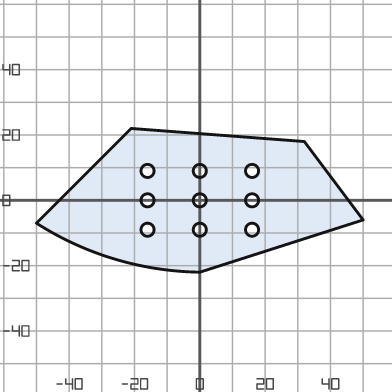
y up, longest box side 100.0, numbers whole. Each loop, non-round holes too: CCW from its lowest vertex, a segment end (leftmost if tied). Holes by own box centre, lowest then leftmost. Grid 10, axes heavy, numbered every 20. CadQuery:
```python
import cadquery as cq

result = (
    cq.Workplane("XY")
    .moveTo(0.0, -22.0)
    .lineTo(50.0, -6.0)
    .lineTo(32.0, 18.0)
    .lineTo(-21.0, 22.0)
    .lineTo(-50.0, -7.0)
    .threePointArc((-26.0, -18.0), (0.0, -22.0))
    .close()
    .moveTo(-16.0, -9.0)
    .circle(2.0)
    .moveTo(0.0, -9.0)
    .circle(2.0)
    .moveTo(16.0, -9.0)
    .circle(2.0)
    .moveTo(-16.0, 0.0)
    .circle(2.0)
    .moveTo(0.0, 0.0)
    .circle(2.0)
    .moveTo(16.0, 0.0)
    .circle(2.0)
    .moveTo(-16.0, 9.0)
    .circle(2.0)
    .moveTo(0.0, 9.0)
    .circle(2.0)
    .moveTo(16.0, 9.0)
    .circle(2.0)
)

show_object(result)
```